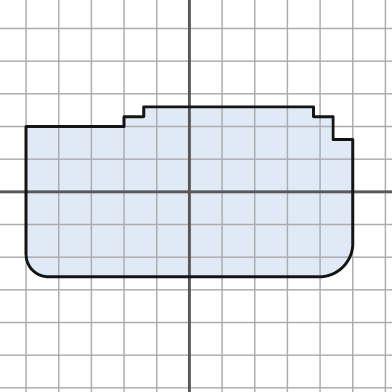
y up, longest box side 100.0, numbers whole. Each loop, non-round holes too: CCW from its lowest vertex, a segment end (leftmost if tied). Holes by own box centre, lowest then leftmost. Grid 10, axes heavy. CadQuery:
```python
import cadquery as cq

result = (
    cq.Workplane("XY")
    .moveTo(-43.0, -26.0)
    .lineTo(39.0, -26.0)
    .threePointArc((47.0, -23.0), (50.0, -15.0))
    .lineTo(50.0, 16.0)
    .lineTo(44.0, 16.0)
    .lineTo(44.0, 23.0)
    .lineTo(38.0, 23.0)
    .lineTo(38.0, 26.0)
    .lineTo(-14.0, 26.0)
    .lineTo(-14.0, 23.0)
    .lineTo(-20.0, 23.0)
    .lineTo(-20.0, 20.0)
    .lineTo(-50.0, 20.0)
    .lineTo(-50.0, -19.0)
    .threePointArc((-48.0, -24.0), (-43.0, -26.0))
    .close()
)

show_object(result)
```